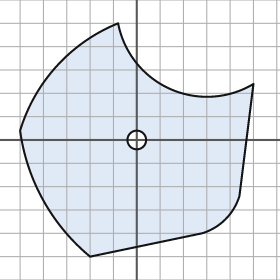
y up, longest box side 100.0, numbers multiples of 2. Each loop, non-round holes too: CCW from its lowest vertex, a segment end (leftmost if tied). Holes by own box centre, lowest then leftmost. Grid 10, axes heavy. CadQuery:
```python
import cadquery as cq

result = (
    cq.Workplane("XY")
    .moveTo(-20.0, -50.0)
    .lineTo(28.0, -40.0)
    .threePointArc((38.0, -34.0), (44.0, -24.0))
    .lineTo(50.0, 24.0)
    .threePointArc((14.0, 22.0), (-8.0, 50.0))
    .threePointArc((-34.0, 32.0), (-50.0, 4.0))
    .threePointArc((-40.0, -26.0), (-20.0, -50.0))
    .close()
    .moveTo(0.0, 0.0)
    .circle(4.0)
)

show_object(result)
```